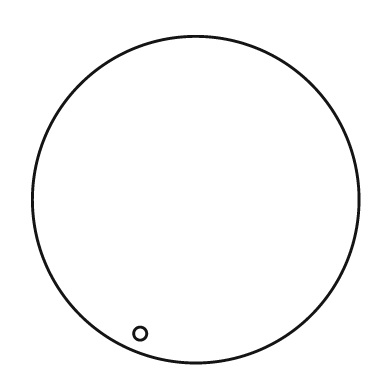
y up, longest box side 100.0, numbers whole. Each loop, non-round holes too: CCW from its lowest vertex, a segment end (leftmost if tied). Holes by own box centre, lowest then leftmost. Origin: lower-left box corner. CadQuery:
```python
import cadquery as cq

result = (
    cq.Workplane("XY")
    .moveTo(50.0, 50.0)
    .circle(50.0)
    .moveTo(33.0, 9.0)
    .circle(2.0)
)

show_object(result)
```